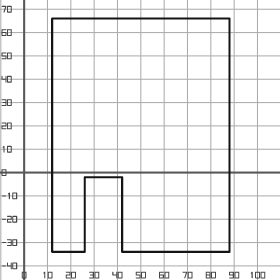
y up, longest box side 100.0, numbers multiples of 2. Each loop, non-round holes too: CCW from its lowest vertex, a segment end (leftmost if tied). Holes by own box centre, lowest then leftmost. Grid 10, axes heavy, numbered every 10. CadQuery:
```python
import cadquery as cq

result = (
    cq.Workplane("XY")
    .moveTo(12.0, -34.0)
    .lineTo(26.0, -34.0)
    .lineTo(26.0, -2.0)
    .lineTo(42.0, -2.0)
    .lineTo(42.0, -34.0)
    .lineTo(88.0, -34.0)
    .lineTo(88.0, 66.0)
    .lineTo(12.0, 66.0)
    .close()
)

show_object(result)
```